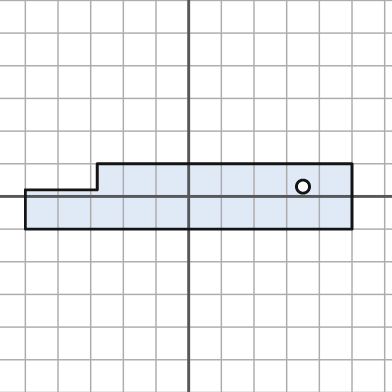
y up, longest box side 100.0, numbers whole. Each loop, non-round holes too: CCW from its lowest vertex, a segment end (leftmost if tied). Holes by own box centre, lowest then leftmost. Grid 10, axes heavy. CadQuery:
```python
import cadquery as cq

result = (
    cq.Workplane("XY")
    .moveTo(-50.0, -10.0)
    .lineTo(50.0, -10.0)
    .lineTo(50.0, 10.0)
    .lineTo(-28.0, 10.0)
    .lineTo(-28.0, 2.0)
    .lineTo(-50.0, 2.0)
    .close()
    .moveTo(35.0, 3.0)
    .circle(2.0)
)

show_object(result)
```